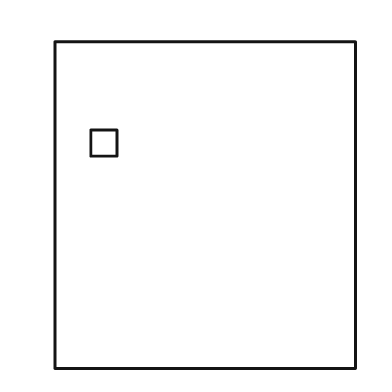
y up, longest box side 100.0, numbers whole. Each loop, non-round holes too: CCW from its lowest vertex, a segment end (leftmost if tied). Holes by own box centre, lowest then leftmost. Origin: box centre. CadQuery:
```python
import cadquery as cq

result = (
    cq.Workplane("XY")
    .moveTo(-46.0, -50.0)
    .lineTo(46.0, -50.0)
    .lineTo(46.0, 50.0)
    .lineTo(-46.0, 50.0)
    .close()
    .moveTo(-35.0, 15.0)
    .lineTo(-27.0, 15.0)
    .lineTo(-27.0, 23.0)
    .lineTo(-35.0, 23.0)
    .close()
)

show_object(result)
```